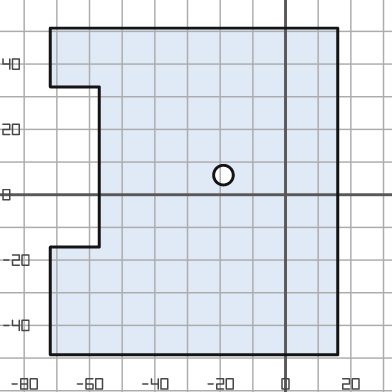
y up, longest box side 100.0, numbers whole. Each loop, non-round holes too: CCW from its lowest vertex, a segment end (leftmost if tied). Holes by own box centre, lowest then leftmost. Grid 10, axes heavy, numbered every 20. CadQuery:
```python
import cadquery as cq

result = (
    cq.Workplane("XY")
    .moveTo(-72.0, -49.0)
    .lineTo(16.0, -49.0)
    .lineTo(16.0, 51.0)
    .lineTo(-72.0, 51.0)
    .lineTo(-72.0, 33.0)
    .lineTo(-57.0, 33.0)
    .lineTo(-57.0, -16.0)
    .lineTo(-72.0, -16.0)
    .close()
    .moveTo(-19.0, 6.0)
    .circle(3.0)
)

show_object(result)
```